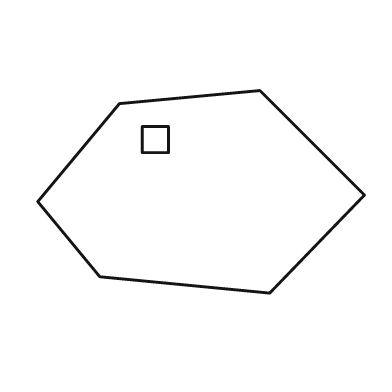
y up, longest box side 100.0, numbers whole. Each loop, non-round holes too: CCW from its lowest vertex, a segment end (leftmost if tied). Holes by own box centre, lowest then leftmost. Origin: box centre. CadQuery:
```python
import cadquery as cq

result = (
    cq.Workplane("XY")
    .moveTo(21.0, -31.0)
    .lineTo(50.0, -1.0)
    .lineTo(18.0, 31.0)
    .lineTo(-25.0, 27.0)
    .lineTo(-50.0, -3.0)
    .lineTo(-31.0, -26.0)
    .close()
    .moveTo(-18.0, 12.0)
    .lineTo(-10.0, 12.0)
    .lineTo(-10.0, 20.0)
    .lineTo(-18.0, 20.0)
    .close()
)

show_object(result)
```